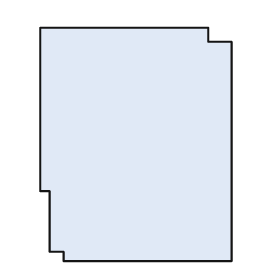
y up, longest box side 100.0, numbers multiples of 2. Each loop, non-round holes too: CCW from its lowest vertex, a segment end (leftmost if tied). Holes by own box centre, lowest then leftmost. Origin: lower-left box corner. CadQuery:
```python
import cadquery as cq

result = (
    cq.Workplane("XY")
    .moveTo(10.0, 0.0)
    .lineTo(82.0, 0.0)
    .lineTo(82.0, 94.0)
    .lineTo(72.0, 94.0)
    .lineTo(72.0, 100.0)
    .lineTo(0.0, 100.0)
    .lineTo(0.0, 30.0)
    .lineTo(4.0, 30.0)
    .lineTo(4.0, 4.0)
    .lineTo(10.0, 4.0)
    .close()
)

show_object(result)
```